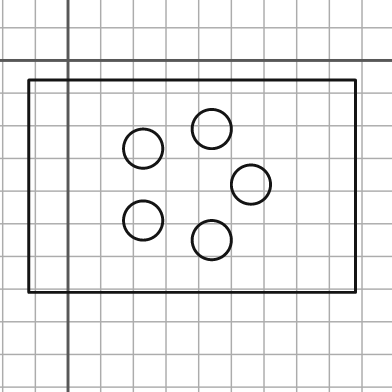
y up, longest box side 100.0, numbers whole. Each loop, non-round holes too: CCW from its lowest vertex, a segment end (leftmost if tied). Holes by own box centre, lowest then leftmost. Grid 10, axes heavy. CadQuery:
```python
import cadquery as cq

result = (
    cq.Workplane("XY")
    .moveTo(-12.0, -71.0)
    .lineTo(88.0, -71.0)
    .lineTo(88.0, -6.0)
    .lineTo(-12.0, -6.0)
    .close()
    .moveTo(44.0, -55.0)
    .circle(6.0)
    .moveTo(23.0, -49.0)
    .circle(6.0)
    .moveTo(56.0, -38.0)
    .circle(6.0)
    .moveTo(23.0, -27.0)
    .circle(6.0)
    .moveTo(44.0, -21.0)
    .circle(6.0)
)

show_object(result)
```